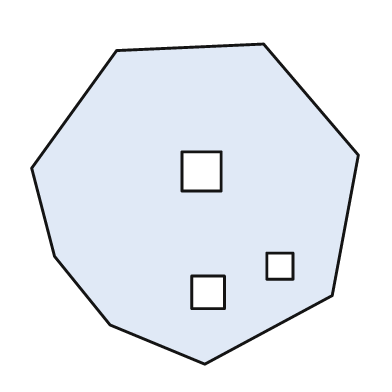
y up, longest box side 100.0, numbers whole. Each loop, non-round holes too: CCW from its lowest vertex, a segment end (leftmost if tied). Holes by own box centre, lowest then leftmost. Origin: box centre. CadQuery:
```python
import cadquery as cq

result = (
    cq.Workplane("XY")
    .moveTo(3.0, -49.0)
    .lineTo(42.0, -28.0)
    .lineTo(50.0, 15.0)
    .lineTo(21.0, 49.0)
    .lineTo(-24.0, 47.0)
    .lineTo(-50.0, 11.0)
    .lineTo(-43.0, -16.0)
    .lineTo(-26.0, -37.0)
    .close()
    .moveTo(-1.0, -32.0)
    .lineTo(9.0, -32.0)
    .lineTo(9.0, -22.0)
    .lineTo(-1.0, -22.0)
    .close()
    .moveTo(22.0, -23.0)
    .lineTo(30.0, -23.0)
    .lineTo(30.0, -15.0)
    .lineTo(22.0, -15.0)
    .close()
    .moveTo(-4.0, 4.0)
    .lineTo(8.0, 4.0)
    .lineTo(8.0, 16.0)
    .lineTo(-4.0, 16.0)
    .close()
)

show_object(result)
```